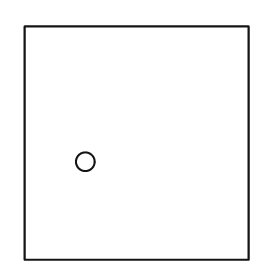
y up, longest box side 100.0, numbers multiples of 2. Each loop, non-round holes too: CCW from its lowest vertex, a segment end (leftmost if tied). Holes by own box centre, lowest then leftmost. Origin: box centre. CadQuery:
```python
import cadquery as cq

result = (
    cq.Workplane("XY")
    .moveTo(-48.0, -50.0)
    .lineTo(48.0, -50.0)
    .lineTo(48.0, 50.0)
    .lineTo(-48.0, 50.0)
    .close()
    .moveTo(-22.0, -8.0)
    .circle(4.0)
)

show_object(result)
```